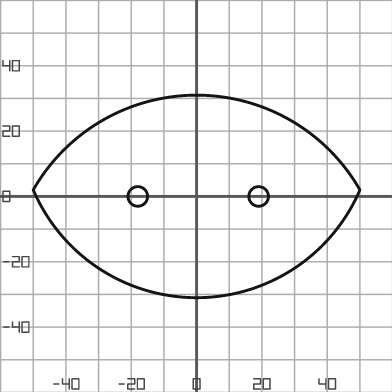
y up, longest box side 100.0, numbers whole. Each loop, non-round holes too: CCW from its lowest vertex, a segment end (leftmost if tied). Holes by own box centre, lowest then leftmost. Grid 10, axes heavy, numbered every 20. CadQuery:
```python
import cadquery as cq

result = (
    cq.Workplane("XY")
    .moveTo(-50.0, 2.0)
    .threePointArc((0.0, -31.0), (50.0, 2.0))
    .threePointArc((0.0, 31.0), (-50.0, 2.0))
    .close()
    .moveTo(-18.0, 0.0)
    .circle(3.0)
    .moveTo(19.0, 0.0)
    .circle(3.0)
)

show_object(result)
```